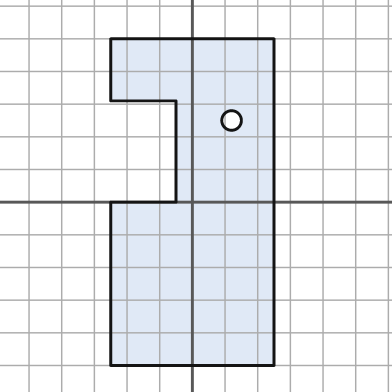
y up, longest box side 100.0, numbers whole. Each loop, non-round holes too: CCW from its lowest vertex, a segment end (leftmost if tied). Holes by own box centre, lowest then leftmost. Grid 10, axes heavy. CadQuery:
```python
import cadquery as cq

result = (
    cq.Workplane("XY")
    .moveTo(-25.0, -50.0)
    .lineTo(25.0, -50.0)
    .lineTo(25.0, 50.0)
    .lineTo(-25.0, 50.0)
    .lineTo(-25.0, 31.0)
    .lineTo(-5.0, 31.0)
    .lineTo(-5.0, 0.0)
    .lineTo(-25.0, 0.0)
    .close()
    .moveTo(12.0, 25.0)
    .circle(3.0)
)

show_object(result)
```